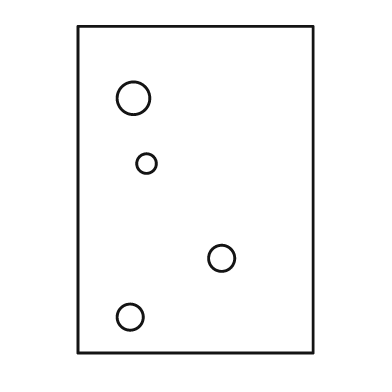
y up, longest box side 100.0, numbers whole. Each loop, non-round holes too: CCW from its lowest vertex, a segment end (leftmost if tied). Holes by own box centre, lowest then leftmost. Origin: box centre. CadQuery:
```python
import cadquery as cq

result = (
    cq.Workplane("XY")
    .moveTo(-36.0, -50.0)
    .lineTo(36.0, -50.0)
    .lineTo(36.0, 50.0)
    .lineTo(-36.0, 50.0)
    .close()
    .moveTo(-20.0, -39.0)
    .circle(4.0)
    .moveTo(8.0, -21.0)
    .circle(4.0)
    .moveTo(-15.0, 8.0)
    .circle(3.0)
    .moveTo(-19.0, 28.0)
    .circle(5.0)
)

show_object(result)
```